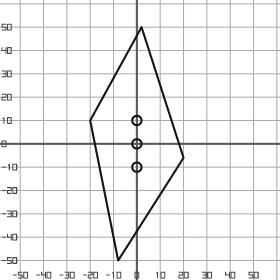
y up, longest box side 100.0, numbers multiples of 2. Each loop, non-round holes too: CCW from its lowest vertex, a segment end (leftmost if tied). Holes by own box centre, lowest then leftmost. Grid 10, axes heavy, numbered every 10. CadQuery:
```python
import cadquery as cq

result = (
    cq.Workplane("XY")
    .moveTo(-8.0, -50.0)
    .lineTo(20.0, -6.0)
    .lineTo(2.0, 50.0)
    .lineTo(-20.0, 10.0)
    .close()
    .moveTo(0.0, -10.0)
    .circle(2.0)
    .moveTo(0.0, 0.0)
    .circle(2.0)
    .moveTo(0.0, 10.0)
    .circle(2.0)
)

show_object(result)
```